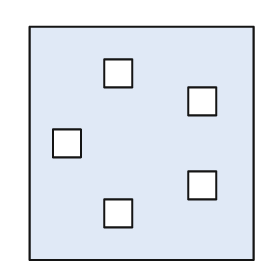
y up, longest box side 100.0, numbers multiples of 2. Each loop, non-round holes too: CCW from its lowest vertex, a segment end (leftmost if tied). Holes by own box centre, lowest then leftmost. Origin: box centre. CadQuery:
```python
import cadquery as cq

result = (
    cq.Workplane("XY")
    .moveTo(-48.0, -50.0)
    .lineTo(48.0, -50.0)
    .lineTo(48.0, 50.0)
    .lineTo(-48.0, 50.0)
    .close()
    .moveTo(-16.0, -36.0)
    .lineTo(-4.0, -36.0)
    .lineTo(-4.0, -24.0)
    .lineTo(-16.0, -24.0)
    .close()
    .moveTo(20.0, -24.0)
    .lineTo(32.0, -24.0)
    .lineTo(32.0, -12.0)
    .lineTo(20.0, -12.0)
    .close()
    .moveTo(-38.0, -6.0)
    .lineTo(-26.0, -6.0)
    .lineTo(-26.0, 6.0)
    .lineTo(-38.0, 6.0)
    .close()
    .moveTo(20.0, 12.0)
    .lineTo(32.0, 12.0)
    .lineTo(32.0, 24.0)
    .lineTo(20.0, 24.0)
    .close()
    .moveTo(-16.0, 24.0)
    .lineTo(-4.0, 24.0)
    .lineTo(-4.0, 36.0)
    .lineTo(-16.0, 36.0)
    .close()
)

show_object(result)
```